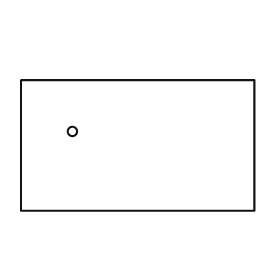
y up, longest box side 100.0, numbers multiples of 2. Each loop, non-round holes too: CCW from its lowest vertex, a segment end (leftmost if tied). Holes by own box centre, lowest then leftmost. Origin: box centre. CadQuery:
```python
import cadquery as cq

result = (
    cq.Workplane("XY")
    .moveTo(-50.0, -28.0)
    .lineTo(50.0, -28.0)
    .lineTo(50.0, 28.0)
    .lineTo(-50.0, 28.0)
    .close()
    .moveTo(-28.0, 6.0)
    .circle(2.0)
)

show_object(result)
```